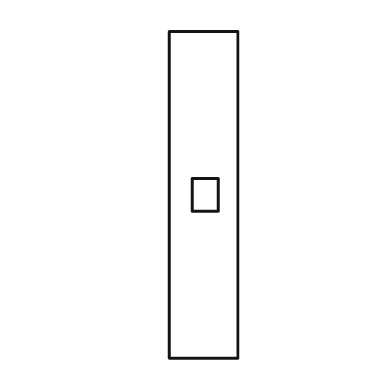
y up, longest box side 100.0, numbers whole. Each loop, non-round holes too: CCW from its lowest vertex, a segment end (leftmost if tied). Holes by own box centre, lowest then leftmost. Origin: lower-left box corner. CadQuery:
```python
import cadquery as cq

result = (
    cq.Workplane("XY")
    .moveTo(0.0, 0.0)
    .lineTo(21.0, 0.0)
    .lineTo(21.0, 100.0)
    .lineTo(0.0, 100.0)
    .close()
    .moveTo(7.0, 45.0)
    .lineTo(15.0, 45.0)
    .lineTo(15.0, 55.0)
    .lineTo(7.0, 55.0)
    .close()
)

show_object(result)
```